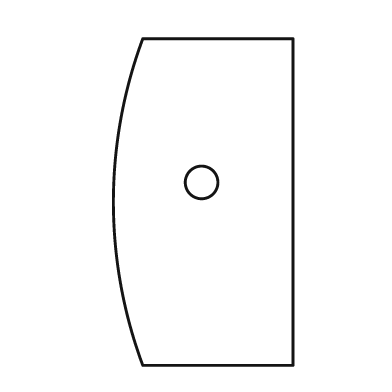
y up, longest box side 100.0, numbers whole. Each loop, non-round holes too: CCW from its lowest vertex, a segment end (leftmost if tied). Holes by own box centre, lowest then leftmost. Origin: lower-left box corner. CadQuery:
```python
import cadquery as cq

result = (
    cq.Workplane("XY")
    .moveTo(9.0, 0.0)
    .lineTo(55.0, 0.0)
    .lineTo(55.0, 100.0)
    .lineTo(9.0, 100.0)
    .threePointArc((0.0, 50.0), (9.0, 0.0))
    .close()
    .moveTo(27.0, 56.0)
    .circle(5.0)
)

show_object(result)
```